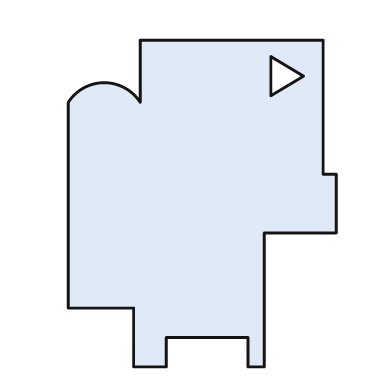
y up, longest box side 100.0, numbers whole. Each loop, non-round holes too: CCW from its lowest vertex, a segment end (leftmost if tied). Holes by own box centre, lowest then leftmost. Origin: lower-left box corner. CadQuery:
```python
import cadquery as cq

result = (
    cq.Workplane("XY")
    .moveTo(20.0, 0.0)
    .lineTo(30.0, 0.0)
    .lineTo(30.0, 9.0)
    .lineTo(55.0, 9.0)
    .lineTo(55.0, 0.0)
    .lineTo(60.0, 0.0)
    .lineTo(60.0, 41.0)
    .lineTo(82.0, 41.0)
    .lineTo(82.0, 59.0)
    .lineTo(78.0, 59.0)
    .lineTo(78.0, 100.0)
    .lineTo(22.0, 100.0)
    .lineTo(22.0, 81.0)
    .threePointArc((11.0, 87.0), (0.0, 81.0))
    .lineTo(0.0, 18.0)
    .lineTo(20.0, 18.0)
    .close()
    .moveTo(62.0, 83.0)
    .lineTo(72.0, 89.0)
    .lineTo(62.0, 95.0)
    .close()
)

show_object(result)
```